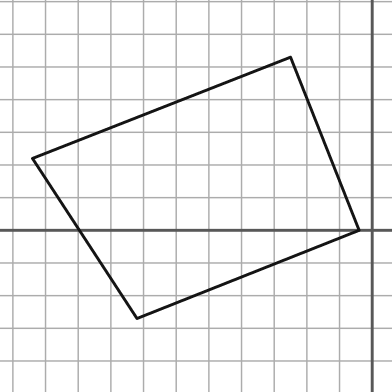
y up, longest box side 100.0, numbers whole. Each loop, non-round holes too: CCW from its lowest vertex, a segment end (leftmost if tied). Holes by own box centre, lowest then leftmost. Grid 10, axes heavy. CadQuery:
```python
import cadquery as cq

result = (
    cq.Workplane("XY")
    .moveTo(-72.0, -27.0)
    .lineTo(-4.0, 0.0)
    .lineTo(-25.0, 53.0)
    .lineTo(-104.0, 22.0)
    .close()
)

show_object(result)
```